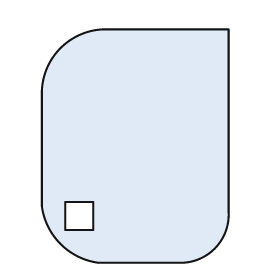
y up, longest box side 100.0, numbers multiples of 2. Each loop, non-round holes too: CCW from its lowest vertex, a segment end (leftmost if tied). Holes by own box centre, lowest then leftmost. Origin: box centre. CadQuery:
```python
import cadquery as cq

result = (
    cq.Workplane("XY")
    .moveTo(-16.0, -50.0)
    .lineTo(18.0, -50.0)
    .threePointArc((34.0, -44.0), (40.0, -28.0))
    .lineTo(40.0, 50.0)
    .lineTo(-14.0, 50.0)
    .threePointArc((-32.0, 42.0), (-40.0, 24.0))
    .lineTo(-40.0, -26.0)
    .threePointArc((-32.0, -42.0), (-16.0, -50.0))
    .close()
    .moveTo(-30.0, -36.0)
    .lineTo(-18.0, -36.0)
    .lineTo(-18.0, -24.0)
    .lineTo(-30.0, -24.0)
    .close()
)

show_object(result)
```